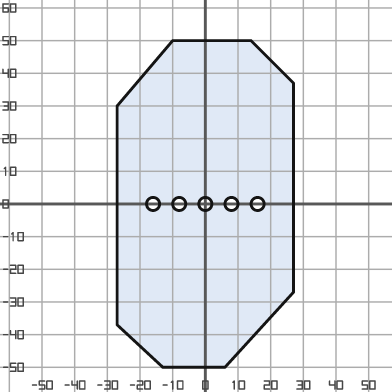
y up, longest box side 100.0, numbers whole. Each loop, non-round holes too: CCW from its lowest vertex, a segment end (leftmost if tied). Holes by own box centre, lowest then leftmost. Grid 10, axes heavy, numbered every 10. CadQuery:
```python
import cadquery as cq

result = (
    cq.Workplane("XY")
    .moveTo(-13.0, -50.0)
    .lineTo(6.0, -50.0)
    .lineTo(27.0, -27.0)
    .lineTo(27.0, 37.0)
    .lineTo(14.0, 50.0)
    .lineTo(-10.0, 50.0)
    .lineTo(-27.0, 30.0)
    .lineTo(-27.0, -37.0)
    .close()
    .moveTo(-16.0, 0.0)
    .circle(2.0)
    .moveTo(-8.0, 0.0)
    .circle(2.0)
    .moveTo(0.0, 0.0)
    .circle(2.0)
    .moveTo(8.0, 0.0)
    .circle(2.0)
    .moveTo(16.0, 0.0)
    .circle(2.0)
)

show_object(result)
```